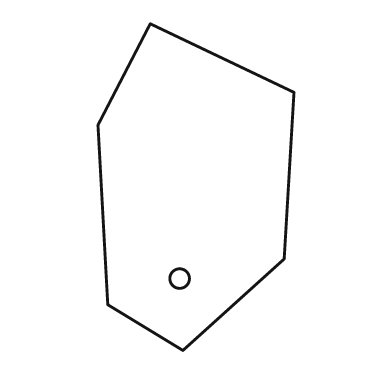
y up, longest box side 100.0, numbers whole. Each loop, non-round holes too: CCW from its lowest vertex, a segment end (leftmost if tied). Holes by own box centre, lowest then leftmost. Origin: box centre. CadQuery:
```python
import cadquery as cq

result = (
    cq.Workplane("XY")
    .moveTo(-4.0, -50.0)
    .lineTo(27.0, -22.0)
    .lineTo(30.0, 29.0)
    .lineTo(-14.0, 50.0)
    .lineTo(-30.0, 19.0)
    .lineTo(-27.0, -36.0)
    .close()
    .moveTo(-5.0, -28.0)
    .circle(3.0)
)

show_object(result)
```